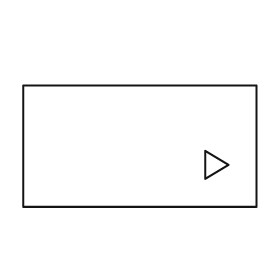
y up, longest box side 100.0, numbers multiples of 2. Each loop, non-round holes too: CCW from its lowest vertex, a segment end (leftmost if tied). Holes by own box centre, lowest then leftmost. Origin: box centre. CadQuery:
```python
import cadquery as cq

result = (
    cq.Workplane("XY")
    .moveTo(-50.0, -26.0)
    .lineTo(50.0, -26.0)
    .lineTo(50.0, 26.0)
    .lineTo(-50.0, 26.0)
    .close()
    .moveTo(28.0, -14.0)
    .lineTo(38.0, -8.0)
    .lineTo(28.0, -2.0)
    .close()
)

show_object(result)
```